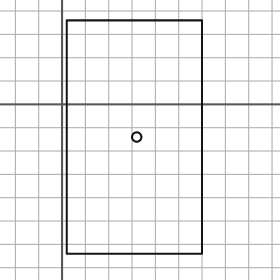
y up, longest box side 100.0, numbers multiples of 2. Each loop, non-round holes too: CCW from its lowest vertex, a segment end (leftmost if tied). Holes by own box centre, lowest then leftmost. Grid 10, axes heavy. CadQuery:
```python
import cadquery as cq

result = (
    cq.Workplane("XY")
    .moveTo(2.0, -64.0)
    .lineTo(60.0, -64.0)
    .lineTo(60.0, 36.0)
    .lineTo(2.0, 36.0)
    .close()
    .moveTo(32.0, -14.0)
    .circle(2.0)
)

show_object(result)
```